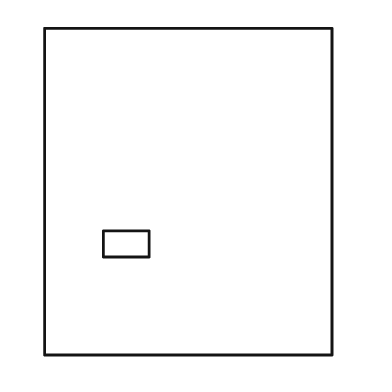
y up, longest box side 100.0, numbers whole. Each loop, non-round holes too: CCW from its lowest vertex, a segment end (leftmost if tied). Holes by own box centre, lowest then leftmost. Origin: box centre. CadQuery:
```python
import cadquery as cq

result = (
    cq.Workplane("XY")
    .moveTo(-44.0, -50.0)
    .lineTo(44.0, -50.0)
    .lineTo(44.0, 50.0)
    .lineTo(-44.0, 50.0)
    .close()
    .moveTo(-26.0, -20.0)
    .lineTo(-12.0, -20.0)
    .lineTo(-12.0, -12.0)
    .lineTo(-26.0, -12.0)
    .close()
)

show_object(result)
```